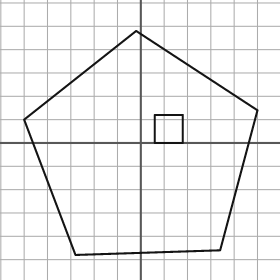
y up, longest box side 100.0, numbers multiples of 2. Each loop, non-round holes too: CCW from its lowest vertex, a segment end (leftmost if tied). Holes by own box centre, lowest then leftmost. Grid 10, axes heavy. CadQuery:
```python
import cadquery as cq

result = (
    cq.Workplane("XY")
    .moveTo(-28.0, -48.0)
    .lineTo(34.0, -46.0)
    .lineTo(50.0, 14.0)
    .lineTo(-2.0, 48.0)
    .lineTo(-50.0, 10.0)
    .close()
    .moveTo(6.0, 0.0)
    .lineTo(18.0, 0.0)
    .lineTo(18.0, 12.0)
    .lineTo(6.0, 12.0)
    .close()
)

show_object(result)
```